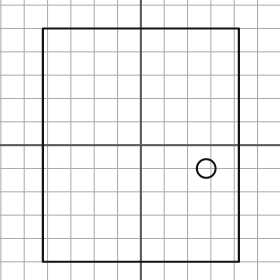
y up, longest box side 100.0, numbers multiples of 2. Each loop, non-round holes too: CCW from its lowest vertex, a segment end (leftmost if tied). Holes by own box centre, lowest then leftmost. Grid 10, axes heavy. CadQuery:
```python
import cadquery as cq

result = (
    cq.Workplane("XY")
    .moveTo(-42.0, -50.0)
    .lineTo(42.0, -50.0)
    .lineTo(42.0, 50.0)
    .lineTo(-42.0, 50.0)
    .close()
    .moveTo(28.0, -10.0)
    .circle(4.0)
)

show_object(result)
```